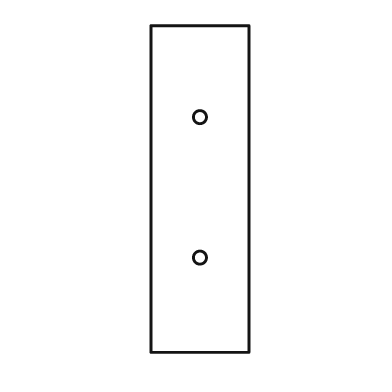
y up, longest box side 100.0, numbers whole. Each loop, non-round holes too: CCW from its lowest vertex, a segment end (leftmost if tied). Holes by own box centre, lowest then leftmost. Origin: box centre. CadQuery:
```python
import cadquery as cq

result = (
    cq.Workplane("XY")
    .moveTo(-15.0, -50.0)
    .lineTo(15.0, -50.0)
    .lineTo(15.0, 50.0)
    .lineTo(-15.0, 50.0)
    .close()
    .moveTo(0.0, -21.0)
    .circle(2.0)
    .moveTo(0.0, 22.0)
    .circle(2.0)
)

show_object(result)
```